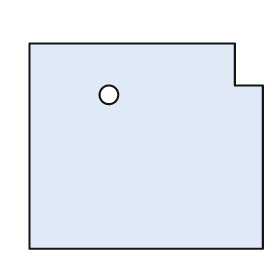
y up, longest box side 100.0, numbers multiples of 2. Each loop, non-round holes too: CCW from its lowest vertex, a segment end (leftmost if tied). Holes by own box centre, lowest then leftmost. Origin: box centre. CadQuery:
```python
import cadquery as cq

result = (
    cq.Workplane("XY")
    .moveTo(-50.0, -44.0)
    .lineTo(50.0, -44.0)
    .lineTo(50.0, 26.0)
    .lineTo(38.0, 26.0)
    .lineTo(38.0, 44.0)
    .lineTo(-50.0, 44.0)
    .close()
    .moveTo(-16.0, 22.0)
    .circle(4.0)
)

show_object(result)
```